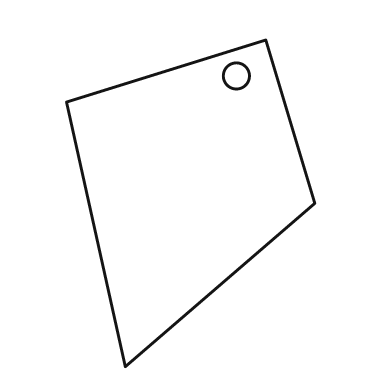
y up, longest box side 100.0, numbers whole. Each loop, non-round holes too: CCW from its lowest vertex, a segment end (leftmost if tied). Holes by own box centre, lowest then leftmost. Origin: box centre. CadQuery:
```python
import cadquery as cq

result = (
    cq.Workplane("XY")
    .moveTo(-20.0, -50.0)
    .lineTo(38.0, 0.0)
    .lineTo(23.0, 50.0)
    .lineTo(-38.0, 31.0)
    .close()
    .moveTo(14.0, 39.0)
    .circle(4.0)
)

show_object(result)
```